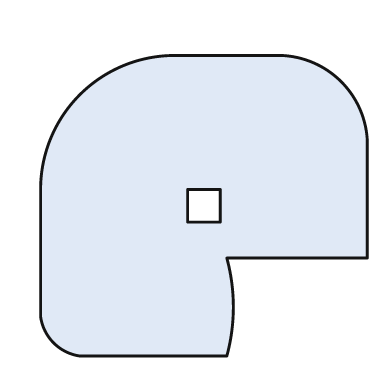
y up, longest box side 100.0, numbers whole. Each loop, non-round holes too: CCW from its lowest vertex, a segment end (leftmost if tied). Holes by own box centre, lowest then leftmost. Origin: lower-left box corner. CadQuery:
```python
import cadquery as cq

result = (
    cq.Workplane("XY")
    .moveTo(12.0, 0.0)
    .lineTo(57.0, 0.0)
    .threePointArc((59.0, 15.0), (57.0, 30.0))
    .lineTo(100.0, 30.0)
    .lineTo(100.0, 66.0)
    .threePointArc((92.0, 84.0), (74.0, 92.0))
    .lineTo(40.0, 92.0)
    .threePointArc((12.0, 80.0), (0.0, 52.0))
    .lineTo(0.0, 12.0)
    .threePointArc((4.0, 4.0), (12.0, 0.0))
    .close()
    .moveTo(45.0, 41.0)
    .lineTo(55.0, 41.0)
    .lineTo(55.0, 51.0)
    .lineTo(45.0, 51.0)
    .close()
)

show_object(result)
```